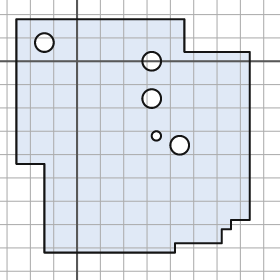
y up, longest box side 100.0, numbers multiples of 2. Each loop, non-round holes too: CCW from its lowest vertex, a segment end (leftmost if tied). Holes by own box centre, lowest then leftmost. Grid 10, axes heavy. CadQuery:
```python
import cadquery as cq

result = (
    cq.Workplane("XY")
    .moveTo(-14.0, -82.0)
    .lineTo(42.0, -82.0)
    .lineTo(42.0, -78.0)
    .lineTo(62.0, -78.0)
    .lineTo(62.0, -72.0)
    .lineTo(66.0, -72.0)
    .lineTo(66.0, -68.0)
    .lineTo(74.0, -68.0)
    .lineTo(74.0, 4.0)
    .lineTo(46.0, 4.0)
    .lineTo(46.0, 18.0)
    .lineTo(-26.0, 18.0)
    .lineTo(-26.0, -44.0)
    .lineTo(-14.0, -44.0)
    .close()
    .moveTo(44.0, -36.0)
    .circle(4.0)
    .moveTo(34.0, -32.0)
    .circle(2.0)
    .moveTo(32.0, -16.0)
    .circle(4.0)
    .moveTo(32.0, 0.0)
    .circle(4.0)
    .moveTo(-14.0, 8.0)
    .circle(4.0)
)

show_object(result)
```